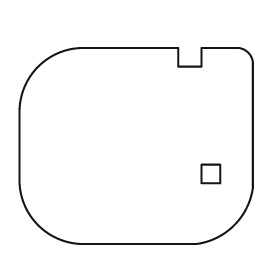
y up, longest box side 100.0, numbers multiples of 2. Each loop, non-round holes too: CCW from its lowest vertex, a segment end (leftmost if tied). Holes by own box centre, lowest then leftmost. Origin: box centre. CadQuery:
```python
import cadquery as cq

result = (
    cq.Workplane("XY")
    .moveTo(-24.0, -42.0)
    .lineTo(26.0, -42.0)
    .threePointArc((42.0, -34.0), (50.0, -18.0))
    .lineTo(50.0, 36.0)
    .threePointArc((48.0, 40.0), (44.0, 42.0))
    .lineTo(28.0, 42.0)
    .lineTo(28.0, 34.0)
    .lineTo(18.0, 34.0)
    .lineTo(18.0, 42.0)
    .lineTo(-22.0, 42.0)
    .threePointArc((-42.0, 34.0), (-50.0, 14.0))
    .lineTo(-50.0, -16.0)
    .threePointArc((-42.0, -34.0), (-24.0, -42.0))
    .close()
    .moveTo(28.0, -16.0)
    .lineTo(36.0, -16.0)
    .lineTo(36.0, -8.0)
    .lineTo(28.0, -8.0)
    .close()
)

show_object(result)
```